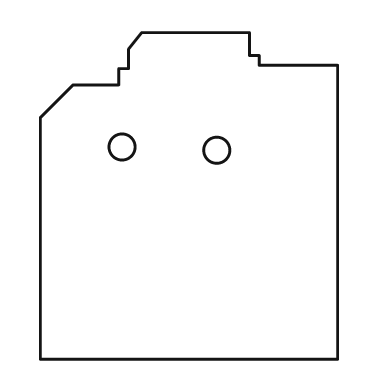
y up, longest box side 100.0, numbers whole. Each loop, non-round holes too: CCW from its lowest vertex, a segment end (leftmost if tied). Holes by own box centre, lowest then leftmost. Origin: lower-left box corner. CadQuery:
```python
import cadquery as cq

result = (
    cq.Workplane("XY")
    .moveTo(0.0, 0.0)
    .lineTo(91.0, 0.0)
    .lineTo(91.0, 90.0)
    .lineTo(67.0, 90.0)
    .lineTo(67.0, 93.0)
    .lineTo(64.0, 93.0)
    .lineTo(64.0, 100.0)
    .lineTo(31.0, 100.0)
    .lineTo(27.0, 95.0)
    .lineTo(27.0, 89.0)
    .lineTo(24.0, 89.0)
    .lineTo(24.0, 84.0)
    .lineTo(10.0, 84.0)
    .lineTo(0.0, 74.0)
    .close()
    .moveTo(54.0, 64.0)
    .circle(4.0)
    .moveTo(25.0, 65.0)
    .circle(4.0)
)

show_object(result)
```